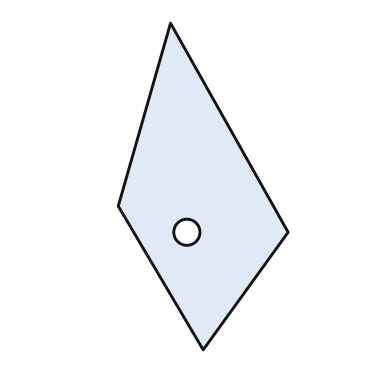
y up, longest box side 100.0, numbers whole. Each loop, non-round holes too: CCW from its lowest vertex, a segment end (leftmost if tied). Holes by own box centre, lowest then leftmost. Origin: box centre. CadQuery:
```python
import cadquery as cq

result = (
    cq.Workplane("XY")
    .moveTo(0.0, -50.0)
    .lineTo(26.0, -14.0)
    .lineTo(-10.0, 50.0)
    .lineTo(-26.0, -6.0)
    .close()
    .moveTo(-5.0, -14.0)
    .circle(4.0)
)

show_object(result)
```